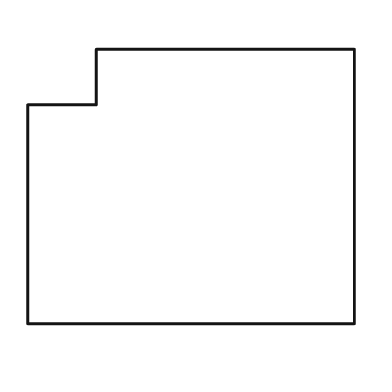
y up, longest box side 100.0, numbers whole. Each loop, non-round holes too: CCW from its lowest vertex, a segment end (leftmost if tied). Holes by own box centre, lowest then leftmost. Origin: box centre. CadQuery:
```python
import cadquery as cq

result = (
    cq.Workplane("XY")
    .moveTo(-50.0, -42.0)
    .lineTo(50.0, -42.0)
    .lineTo(50.0, 42.0)
    .lineTo(-29.0, 42.0)
    .lineTo(-29.0, 25.0)
    .lineTo(-50.0, 25.0)
    .close()
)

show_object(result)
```